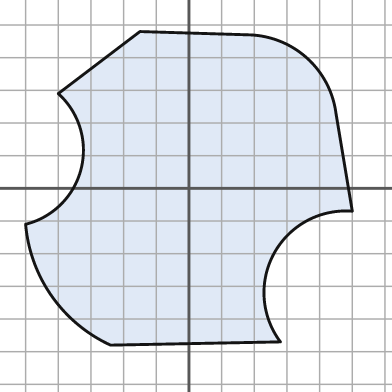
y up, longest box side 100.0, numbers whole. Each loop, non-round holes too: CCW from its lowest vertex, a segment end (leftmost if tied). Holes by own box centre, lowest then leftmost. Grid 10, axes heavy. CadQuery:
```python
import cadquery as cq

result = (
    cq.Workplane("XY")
    .moveTo(-24.0, -48.0)
    .lineTo(28.0, -47.0)
    .threePointArc((26.0, -20.0), (50.0, -7.0))
    .lineTo(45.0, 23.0)
    .threePointArc((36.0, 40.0), (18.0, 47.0))
    .lineTo(-15.0, 48.0)
    .lineTo(-40.0, 29.0)
    .threePointArc((-33.0, 6.0), (-50.0, -11.0))
    .threePointArc((-42.0, -33.0), (-24.0, -48.0))
    .close()
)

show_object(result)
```